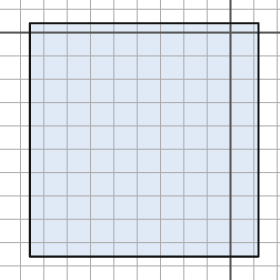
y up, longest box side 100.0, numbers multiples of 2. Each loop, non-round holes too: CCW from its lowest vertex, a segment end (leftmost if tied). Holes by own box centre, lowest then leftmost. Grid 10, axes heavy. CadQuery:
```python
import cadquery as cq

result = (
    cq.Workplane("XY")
    .moveTo(-86.0, -96.0)
    .lineTo(12.0, -96.0)
    .lineTo(12.0, 4.0)
    .lineTo(-86.0, 4.0)
    .close()
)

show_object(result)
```